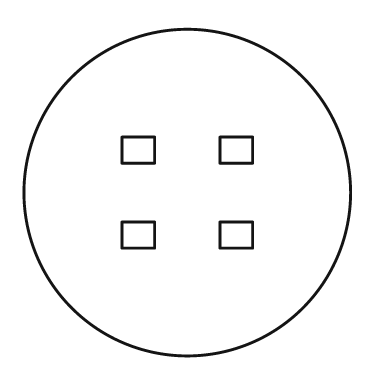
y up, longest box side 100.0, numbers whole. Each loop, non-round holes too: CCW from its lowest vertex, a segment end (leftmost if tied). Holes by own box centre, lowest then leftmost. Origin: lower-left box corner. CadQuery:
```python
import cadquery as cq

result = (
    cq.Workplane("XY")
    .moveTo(50.0, 50.0)
    .circle(50.0)
    .moveTo(30.0, 33.0)
    .lineTo(40.0, 33.0)
    .lineTo(40.0, 41.0)
    .lineTo(30.0, 41.0)
    .close()
    .moveTo(60.0, 33.0)
    .lineTo(70.0, 33.0)
    .lineTo(70.0, 41.0)
    .lineTo(60.0, 41.0)
    .close()
    .moveTo(30.0, 59.0)
    .lineTo(40.0, 59.0)
    .lineTo(40.0, 67.0)
    .lineTo(30.0, 67.0)
    .close()
    .moveTo(60.0, 59.0)
    .lineTo(70.0, 59.0)
    .lineTo(70.0, 67.0)
    .lineTo(60.0, 67.0)
    .close()
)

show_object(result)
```